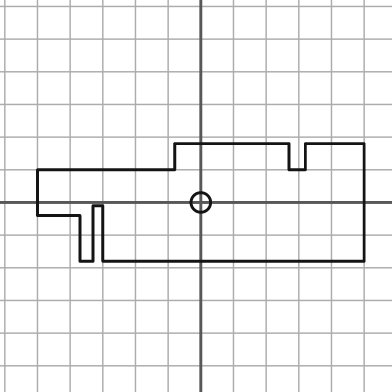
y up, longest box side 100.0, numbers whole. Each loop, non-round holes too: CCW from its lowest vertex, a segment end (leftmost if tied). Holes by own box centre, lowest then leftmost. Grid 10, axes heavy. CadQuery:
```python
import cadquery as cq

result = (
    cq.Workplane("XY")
    .moveTo(-37.0, -18.0)
    .lineTo(-33.0, -18.0)
    .lineTo(-33.0, -1.0)
    .lineTo(-30.0, -1.0)
    .lineTo(-30.0, -18.0)
    .lineTo(50.0, -18.0)
    .lineTo(50.0, 18.0)
    .lineTo(32.0, 18.0)
    .lineTo(32.0, 10.0)
    .lineTo(27.0, 10.0)
    .lineTo(27.0, 18.0)
    .lineTo(-8.0, 18.0)
    .lineTo(-8.0, 10.0)
    .lineTo(-50.0, 10.0)
    .lineTo(-50.0, -4.0)
    .lineTo(-37.0, -4.0)
    .close()
    .moveTo(0.0, 0.0)
    .circle(3.0)
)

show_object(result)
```